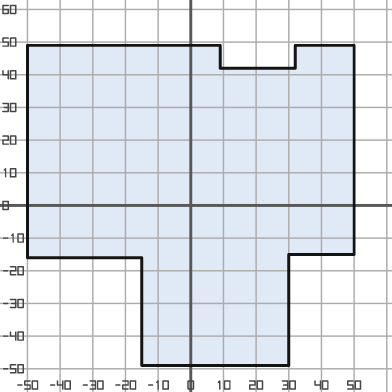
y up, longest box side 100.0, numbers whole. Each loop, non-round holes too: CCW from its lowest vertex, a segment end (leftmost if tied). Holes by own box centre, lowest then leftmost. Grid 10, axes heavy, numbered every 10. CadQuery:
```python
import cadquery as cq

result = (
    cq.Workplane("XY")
    .moveTo(-15.0, -49.0)
    .lineTo(30.0, -49.0)
    .lineTo(30.0, -15.0)
    .lineTo(50.0, -15.0)
    .lineTo(50.0, 49.0)
    .lineTo(32.0, 49.0)
    .lineTo(32.0, 42.0)
    .lineTo(9.0, 42.0)
    .lineTo(9.0, 49.0)
    .lineTo(-50.0, 49.0)
    .lineTo(-50.0, -16.0)
    .lineTo(-15.0, -16.0)
    .close()
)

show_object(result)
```